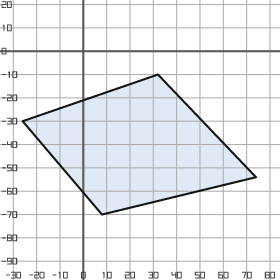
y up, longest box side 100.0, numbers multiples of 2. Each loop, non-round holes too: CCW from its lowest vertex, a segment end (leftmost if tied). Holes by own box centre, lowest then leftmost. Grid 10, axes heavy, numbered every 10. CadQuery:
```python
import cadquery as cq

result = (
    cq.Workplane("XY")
    .moveTo(8.0, -70.0)
    .lineTo(74.0, -54.0)
    .lineTo(32.0, -10.0)
    .lineTo(-26.0, -30.0)
    .close()
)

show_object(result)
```